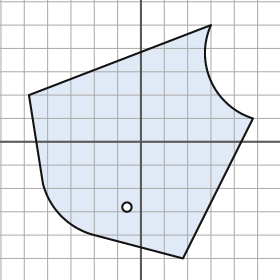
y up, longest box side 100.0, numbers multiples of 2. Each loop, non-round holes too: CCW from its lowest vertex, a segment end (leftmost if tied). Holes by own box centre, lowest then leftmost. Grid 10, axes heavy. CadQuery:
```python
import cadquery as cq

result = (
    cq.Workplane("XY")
    .moveTo(18.0, -50.0)
    .lineTo(48.0, 10.0)
    .threePointArc((30.0, 26.0), (30.0, 50.0))
    .lineTo(-48.0, 20.0)
    .lineTo(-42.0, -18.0)
    .threePointArc((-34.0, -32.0), (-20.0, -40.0))
    .close()
    .moveTo(-6.0, -28.0)
    .circle(2.0)
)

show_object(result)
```